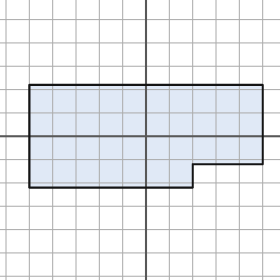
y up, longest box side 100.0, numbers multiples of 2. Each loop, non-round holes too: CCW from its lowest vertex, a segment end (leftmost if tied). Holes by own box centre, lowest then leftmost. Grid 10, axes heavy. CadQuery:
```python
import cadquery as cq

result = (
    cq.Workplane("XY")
    .moveTo(-50.0, -22.0)
    .lineTo(20.0, -22.0)
    .lineTo(20.0, -12.0)
    .lineTo(50.0, -12.0)
    .lineTo(50.0, 22.0)
    .lineTo(-50.0, 22.0)
    .close()
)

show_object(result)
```